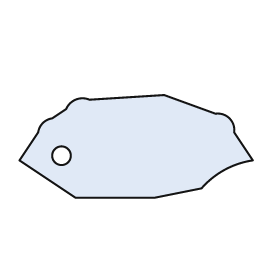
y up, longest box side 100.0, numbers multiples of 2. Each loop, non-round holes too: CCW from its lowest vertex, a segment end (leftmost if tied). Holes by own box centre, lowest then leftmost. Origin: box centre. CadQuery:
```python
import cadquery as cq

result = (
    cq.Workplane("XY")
    .moveTo(-26.0, -22.0)
    .lineTo(8.0, -22.0)
    .lineTo(28.0, -18.0)
    .threePointArc((38.0, -10.0), (50.0, -6.0))
    .lineTo(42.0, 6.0)
    .threePointArc((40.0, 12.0), (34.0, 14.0))
    .lineTo(12.0, 22.0)
    .lineTo(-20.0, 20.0)
    .threePointArc((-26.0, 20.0), (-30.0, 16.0))
    .lineTo(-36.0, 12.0)
    .threePointArc((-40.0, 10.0), (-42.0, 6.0))
    .lineTo(-50.0, -6.0)
    .close()
    .moveTo(-32.0, -4.0)
    .circle(4.0)
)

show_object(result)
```